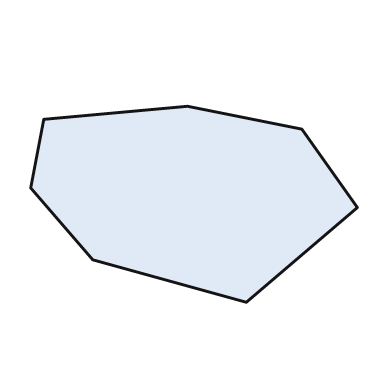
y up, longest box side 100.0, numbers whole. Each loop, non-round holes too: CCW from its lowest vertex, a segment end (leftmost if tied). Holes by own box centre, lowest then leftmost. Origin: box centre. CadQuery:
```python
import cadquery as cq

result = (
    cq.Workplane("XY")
    .moveTo(16.0, -30.0)
    .lineTo(50.0, -1.0)
    .lineTo(33.0, 23.0)
    .lineTo(-2.0, 30.0)
    .lineTo(-46.0, 26.0)
    .lineTo(-50.0, 5.0)
    .lineTo(-31.0, -17.0)
    .close()
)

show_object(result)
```